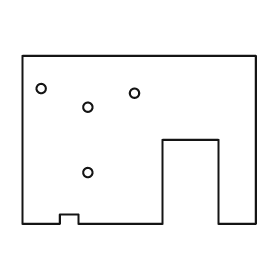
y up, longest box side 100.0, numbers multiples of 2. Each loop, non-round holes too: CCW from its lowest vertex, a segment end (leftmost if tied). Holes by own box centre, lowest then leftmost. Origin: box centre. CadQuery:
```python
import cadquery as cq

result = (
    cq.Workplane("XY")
    .moveTo(-50.0, -36.0)
    .lineTo(-34.0, -36.0)
    .lineTo(-34.0, -32.0)
    .lineTo(-26.0, -32.0)
    .lineTo(-26.0, -36.0)
    .lineTo(10.0, -36.0)
    .lineTo(10.0, 0.0)
    .lineTo(34.0, 0.0)
    .lineTo(34.0, -36.0)
    .lineTo(50.0, -36.0)
    .lineTo(50.0, 36.0)
    .lineTo(-50.0, 36.0)
    .close()
    .moveTo(-22.0, -14.0)
    .circle(2.0)
    .moveTo(-22.0, 14.0)
    .circle(2.0)
    .moveTo(-2.0, 20.0)
    .circle(2.0)
    .moveTo(-42.0, 22.0)
    .circle(2.0)
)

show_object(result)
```